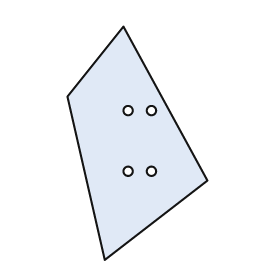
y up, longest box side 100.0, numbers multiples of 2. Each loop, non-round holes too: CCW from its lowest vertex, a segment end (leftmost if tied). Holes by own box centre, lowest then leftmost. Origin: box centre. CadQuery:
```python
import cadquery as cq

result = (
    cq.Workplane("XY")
    .moveTo(-14.0, -50.0)
    .lineTo(30.0, -16.0)
    .lineTo(-6.0, 50.0)
    .lineTo(-30.0, 20.0)
    .close()
    .moveTo(-4.0, -12.0)
    .circle(2.0)
    .moveTo(6.0, -12.0)
    .circle(2.0)
    .moveTo(-4.0, 14.0)
    .circle(2.0)
    .moveTo(6.0, 14.0)
    .circle(2.0)
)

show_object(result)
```